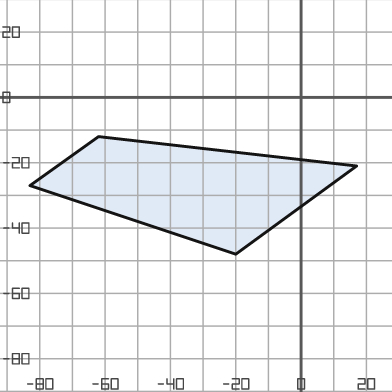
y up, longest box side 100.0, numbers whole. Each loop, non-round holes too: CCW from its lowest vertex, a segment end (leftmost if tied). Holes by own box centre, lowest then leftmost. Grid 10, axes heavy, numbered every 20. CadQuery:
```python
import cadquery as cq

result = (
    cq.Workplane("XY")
    .moveTo(-20.0, -48.0)
    .lineTo(17.0, -21.0)
    .lineTo(-62.0, -12.0)
    .lineTo(-83.0, -27.0)
    .close()
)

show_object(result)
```